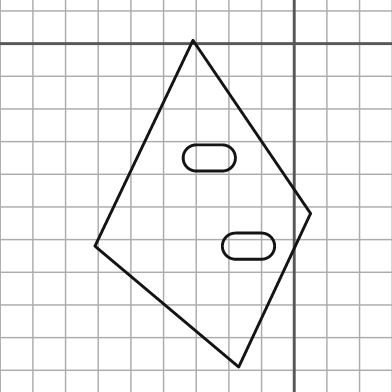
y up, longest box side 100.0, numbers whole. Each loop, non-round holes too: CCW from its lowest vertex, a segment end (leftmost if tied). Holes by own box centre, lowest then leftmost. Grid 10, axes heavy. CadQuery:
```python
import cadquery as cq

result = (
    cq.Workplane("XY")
    .moveTo(-17.0, -99.0)
    .lineTo(5.0, -52.0)
    .lineTo(-31.0, 1.0)
    .lineTo(-61.0, -62.0)
    .close()
    .moveTo(-18.0, -66.0)
    .lineTo(-10.0, -66.0)
    .threePointArc((-6.0, -62.0), (-10.0, -58.0))
    .lineTo(-18.0, -58.0)
    .threePointArc((-22.0, -62.0), (-18.0, -66.0))
    .close()
    .moveTo(-30.0, -39.0)
    .lineTo(-22.0, -39.0)
    .threePointArc((-18.0, -35.0), (-22.0, -31.0))
    .lineTo(-30.0, -31.0)
    .threePointArc((-34.0, -35.0), (-30.0, -39.0))
    .close()
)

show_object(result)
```